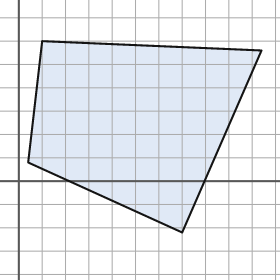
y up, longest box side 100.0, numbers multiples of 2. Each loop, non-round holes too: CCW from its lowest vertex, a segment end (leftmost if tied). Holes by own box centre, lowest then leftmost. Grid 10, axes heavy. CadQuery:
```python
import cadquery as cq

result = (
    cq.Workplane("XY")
    .moveTo(70.0, -22.0)
    .lineTo(104.0, 56.0)
    .lineTo(10.0, 60.0)
    .lineTo(4.0, 8.0)
    .close()
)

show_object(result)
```